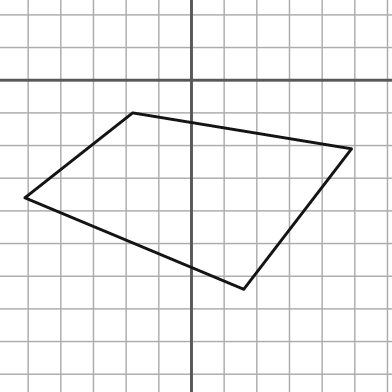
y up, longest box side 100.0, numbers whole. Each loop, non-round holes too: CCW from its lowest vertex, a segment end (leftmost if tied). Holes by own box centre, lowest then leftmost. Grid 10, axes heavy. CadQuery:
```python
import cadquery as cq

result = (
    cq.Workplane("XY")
    .moveTo(16.0, -64.0)
    .lineTo(49.0, -21.0)
    .lineTo(-18.0, -10.0)
    .lineTo(-51.0, -36.0)
    .close()
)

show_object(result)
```